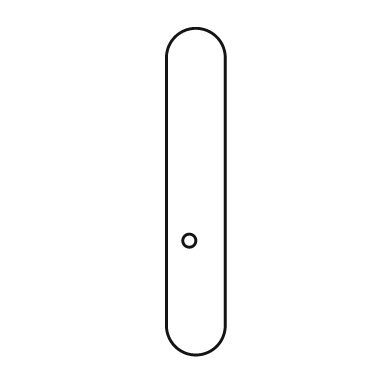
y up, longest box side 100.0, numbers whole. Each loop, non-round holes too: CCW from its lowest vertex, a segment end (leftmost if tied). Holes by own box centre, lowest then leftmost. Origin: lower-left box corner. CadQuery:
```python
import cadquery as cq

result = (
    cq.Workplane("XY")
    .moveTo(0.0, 9.0)
    .threePointArc((9.0, 0.0), (18.0, 9.0))
    .lineTo(18.0, 91.0)
    .threePointArc((9.0, 100.0), (0.0, 91.0))
    .close()
    .moveTo(7.0, 35.0)
    .circle(2.0)
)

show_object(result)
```